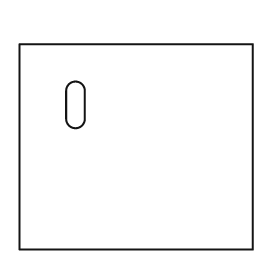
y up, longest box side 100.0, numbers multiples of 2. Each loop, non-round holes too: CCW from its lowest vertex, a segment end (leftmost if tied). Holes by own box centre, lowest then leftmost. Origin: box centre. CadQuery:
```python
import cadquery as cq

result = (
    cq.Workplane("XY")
    .moveTo(-50.0, -44.0)
    .lineTo(50.0, -44.0)
    .lineTo(50.0, 44.0)
    .lineTo(-50.0, 44.0)
    .close()
    .moveTo(-30.0, 12.0)
    .threePointArc((-26.0, 8.0), (-22.0, 12.0))
    .lineTo(-22.0, 24.0)
    .threePointArc((-26.0, 28.0), (-30.0, 24.0))
    .close()
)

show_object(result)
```